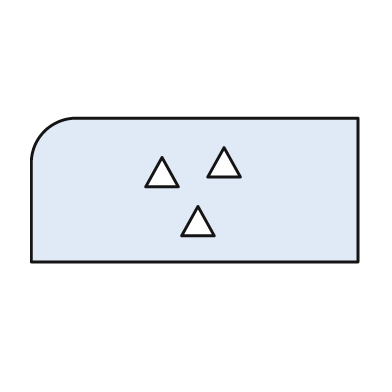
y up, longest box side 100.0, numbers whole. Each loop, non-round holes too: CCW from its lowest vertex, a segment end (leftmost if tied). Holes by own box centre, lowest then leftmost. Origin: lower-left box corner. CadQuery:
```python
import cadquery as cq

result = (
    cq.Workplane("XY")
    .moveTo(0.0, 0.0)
    .lineTo(100.0, 0.0)
    .lineTo(100.0, 44.0)
    .lineTo(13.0, 44.0)
    .threePointArc((4.0, 40.0), (0.0, 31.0))
    .close()
    .moveTo(46.0, 8.0)
    .lineTo(56.0, 8.0)
    .lineTo(51.0, 17.0)
    .close()
    .moveTo(35.0, 23.0)
    .lineTo(45.0, 23.0)
    .lineTo(40.0, 32.0)
    .close()
    .moveTo(54.0, 26.0)
    .lineTo(64.0, 26.0)
    .lineTo(59.0, 35.0)
    .close()
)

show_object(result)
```